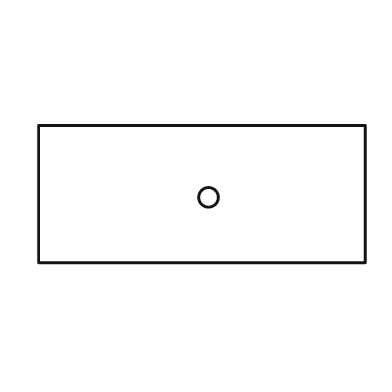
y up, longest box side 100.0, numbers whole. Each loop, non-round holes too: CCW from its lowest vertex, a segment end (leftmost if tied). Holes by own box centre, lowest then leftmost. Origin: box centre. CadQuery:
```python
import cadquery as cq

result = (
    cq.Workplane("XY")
    .moveTo(-50.0, -21.0)
    .lineTo(50.0, -21.0)
    .lineTo(50.0, 21.0)
    .lineTo(-50.0, 21.0)
    .close()
    .moveTo(2.0, -1.0)
    .circle(3.0)
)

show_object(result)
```